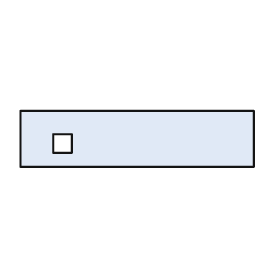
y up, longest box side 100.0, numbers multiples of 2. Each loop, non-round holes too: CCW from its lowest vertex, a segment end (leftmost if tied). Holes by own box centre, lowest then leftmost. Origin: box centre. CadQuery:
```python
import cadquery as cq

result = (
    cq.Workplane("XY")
    .moveTo(-50.0, -12.0)
    .lineTo(50.0, -12.0)
    .lineTo(50.0, 12.0)
    .lineTo(-50.0, 12.0)
    .close()
    .moveTo(-36.0, -6.0)
    .lineTo(-28.0, -6.0)
    .lineTo(-28.0, 2.0)
    .lineTo(-36.0, 2.0)
    .close()
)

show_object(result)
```